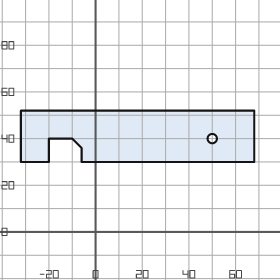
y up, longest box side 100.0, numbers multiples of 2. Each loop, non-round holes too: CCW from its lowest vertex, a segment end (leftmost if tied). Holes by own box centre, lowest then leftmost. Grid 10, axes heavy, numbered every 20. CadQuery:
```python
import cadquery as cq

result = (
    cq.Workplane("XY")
    .moveTo(-32.0, 30.0)
    .lineTo(-20.0, 30.0)
    .lineTo(-20.0, 40.0)
    .lineTo(-10.0, 40.0)
    .lineTo(-6.0, 36.0)
    .lineTo(-6.0, 30.0)
    .lineTo(68.0, 30.0)
    .lineTo(68.0, 52.0)
    .lineTo(-32.0, 52.0)
    .close()
    .moveTo(50.0, 40.0)
    .circle(2.0)
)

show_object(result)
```